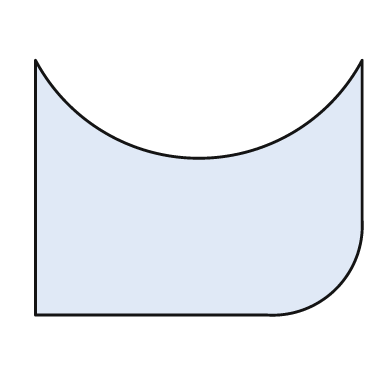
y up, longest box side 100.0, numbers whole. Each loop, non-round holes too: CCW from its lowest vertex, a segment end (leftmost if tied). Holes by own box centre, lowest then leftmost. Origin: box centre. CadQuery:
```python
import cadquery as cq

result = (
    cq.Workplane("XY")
    .moveTo(-50.0, -39.0)
    .lineTo(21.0, -39.0)
    .threePointArc((42.0, -31.0), (50.0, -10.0))
    .lineTo(50.0, 39.0)
    .threePointArc((0.0, 9.0), (-50.0, 39.0))
    .close()
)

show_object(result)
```